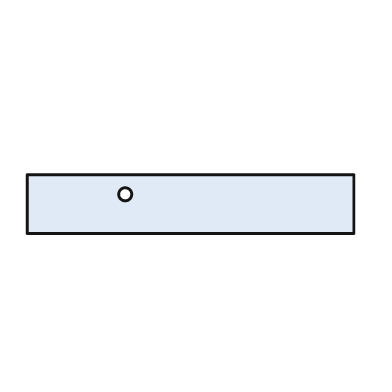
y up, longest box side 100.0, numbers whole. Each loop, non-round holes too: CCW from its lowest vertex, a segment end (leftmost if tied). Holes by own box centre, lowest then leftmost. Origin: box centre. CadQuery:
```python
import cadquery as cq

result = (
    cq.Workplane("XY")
    .moveTo(-50.0, -9.0)
    .lineTo(50.0, -9.0)
    .lineTo(50.0, 9.0)
    .lineTo(-50.0, 9.0)
    .close()
    .moveTo(-20.0, 3.0)
    .circle(2.0)
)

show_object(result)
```